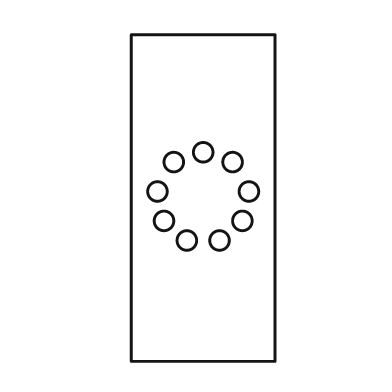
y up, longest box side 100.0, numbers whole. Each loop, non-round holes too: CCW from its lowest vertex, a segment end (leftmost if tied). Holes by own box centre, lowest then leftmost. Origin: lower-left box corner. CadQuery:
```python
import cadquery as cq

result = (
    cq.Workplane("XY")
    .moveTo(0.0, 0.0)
    .lineTo(44.0, 0.0)
    .lineTo(44.0, 100.0)
    .lineTo(0.0, 100.0)
    .close()
    .moveTo(17.0, 37.0)
    .circle(3.0)
    .moveTo(27.0, 37.0)
    .circle(3.0)
    .moveTo(10.0, 43.0)
    .circle(3.0)
    .moveTo(34.0, 43.0)
    .circle(3.0)
    .moveTo(8.0, 52.0)
    .circle(3.0)
    .moveTo(36.0, 52.0)
    .circle(3.0)
    .moveTo(13.0, 61.0)
    .circle(3.0)
    .moveTo(31.0, 61.0)
    .circle(3.0)
    .moveTo(22.0, 64.0)
    .circle(3.0)
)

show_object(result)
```